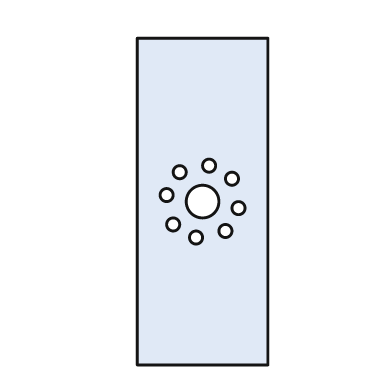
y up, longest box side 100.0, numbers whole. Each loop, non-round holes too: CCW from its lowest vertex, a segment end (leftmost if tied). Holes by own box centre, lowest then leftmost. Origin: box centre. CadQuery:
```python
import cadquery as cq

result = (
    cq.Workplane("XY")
    .moveTo(-20.0, -50.0)
    .lineTo(20.0, -50.0)
    .lineTo(20.0, 50.0)
    .lineTo(-20.0, 50.0)
    .close()
    .moveTo(-2.0, -11.0)
    .circle(2.0)
    .moveTo(7.0, -9.0)
    .circle(2.0)
    .moveTo(-9.0, -7.0)
    .circle(2.0)
    .moveTo(11.0, -2.0)
    .circle(2.0)
    .moveTo(0.0, 0.0)
    .circle(5.0)
    .moveTo(-11.0, 2.0)
    .circle(2.0)
    .moveTo(9.0, 7.0)
    .circle(2.0)
    .moveTo(-7.0, 9.0)
    .circle(2.0)
    .moveTo(2.0, 11.0)
    .circle(2.0)
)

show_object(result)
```